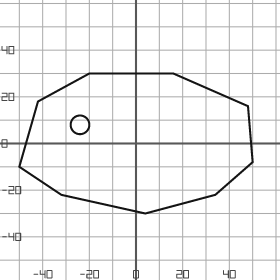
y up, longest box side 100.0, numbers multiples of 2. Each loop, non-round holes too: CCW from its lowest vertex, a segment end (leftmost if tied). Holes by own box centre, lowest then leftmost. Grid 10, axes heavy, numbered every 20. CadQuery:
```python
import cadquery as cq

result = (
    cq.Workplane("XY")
    .moveTo(4.0, -30.0)
    .lineTo(34.0, -22.0)
    .lineTo(50.0, -8.0)
    .lineTo(48.0, 16.0)
    .lineTo(16.0, 30.0)
    .lineTo(-20.0, 30.0)
    .lineTo(-42.0, 18.0)
    .lineTo(-50.0, -10.0)
    .lineTo(-32.0, -22.0)
    .close()
    .moveTo(-24.0, 8.0)
    .circle(4.0)
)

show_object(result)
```